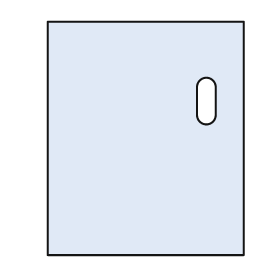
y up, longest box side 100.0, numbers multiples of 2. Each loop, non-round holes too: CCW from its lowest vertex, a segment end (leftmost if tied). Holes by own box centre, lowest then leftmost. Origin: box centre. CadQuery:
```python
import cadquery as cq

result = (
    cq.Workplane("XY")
    .moveTo(-42.0, -50.0)
    .lineTo(42.0, -50.0)
    .lineTo(42.0, 50.0)
    .lineTo(-42.0, 50.0)
    .close()
    .moveTo(22.0, 10.0)
    .threePointArc((26.0, 6.0), (30.0, 10.0))
    .lineTo(30.0, 22.0)
    .threePointArc((26.0, 26.0), (22.0, 22.0))
    .close()
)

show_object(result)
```